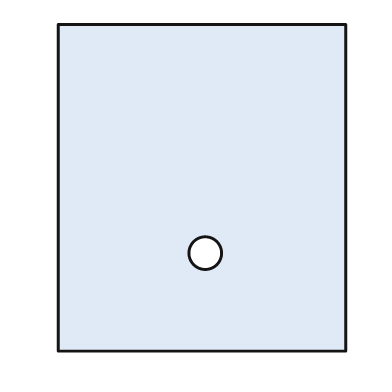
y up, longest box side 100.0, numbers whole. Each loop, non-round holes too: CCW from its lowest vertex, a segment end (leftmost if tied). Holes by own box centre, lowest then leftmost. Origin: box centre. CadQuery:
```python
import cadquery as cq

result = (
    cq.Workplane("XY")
    .moveTo(-44.0, -50.0)
    .lineTo(44.0, -50.0)
    .lineTo(44.0, 50.0)
    .lineTo(-44.0, 50.0)
    .close()
    .moveTo(1.0, -20.0)
    .circle(5.0)
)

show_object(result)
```